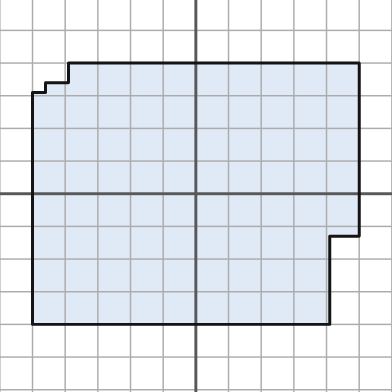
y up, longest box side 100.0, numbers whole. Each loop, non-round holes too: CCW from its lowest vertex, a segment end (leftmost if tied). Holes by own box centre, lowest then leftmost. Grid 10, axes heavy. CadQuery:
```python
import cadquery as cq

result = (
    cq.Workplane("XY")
    .moveTo(-50.0, -40.0)
    .lineTo(41.0, -40.0)
    .lineTo(41.0, -13.0)
    .lineTo(50.0, -13.0)
    .lineTo(50.0, 40.0)
    .lineTo(-39.0, 40.0)
    .lineTo(-39.0, 34.0)
    .lineTo(-46.0, 34.0)
    .lineTo(-46.0, 31.0)
    .lineTo(-50.0, 31.0)
    .close()
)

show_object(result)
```